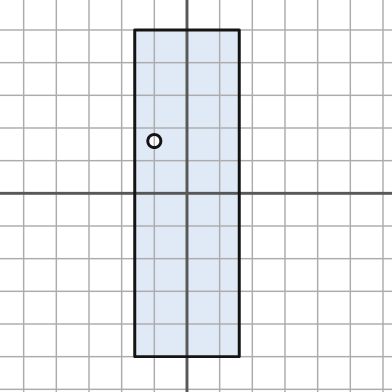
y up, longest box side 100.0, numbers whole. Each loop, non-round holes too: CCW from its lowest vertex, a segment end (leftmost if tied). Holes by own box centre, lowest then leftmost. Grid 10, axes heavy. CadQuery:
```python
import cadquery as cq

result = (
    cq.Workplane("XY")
    .moveTo(-16.0, -50.0)
    .lineTo(16.0, -50.0)
    .lineTo(16.0, 50.0)
    .lineTo(-16.0, 50.0)
    .close()
    .moveTo(-10.0, 16.0)
    .circle(2.0)
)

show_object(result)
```